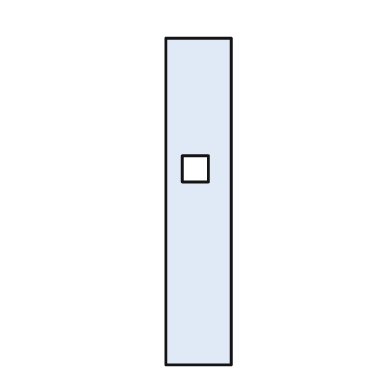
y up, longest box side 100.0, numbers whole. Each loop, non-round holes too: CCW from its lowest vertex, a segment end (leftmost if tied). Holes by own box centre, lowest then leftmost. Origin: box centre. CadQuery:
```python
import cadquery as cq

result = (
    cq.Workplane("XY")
    .moveTo(-10.0, -50.0)
    .lineTo(10.0, -50.0)
    .lineTo(10.0, 50.0)
    .lineTo(-10.0, 50.0)
    .close()
    .moveTo(-5.0, 6.0)
    .lineTo(3.0, 6.0)
    .lineTo(3.0, 14.0)
    .lineTo(-5.0, 14.0)
    .close()
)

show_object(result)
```